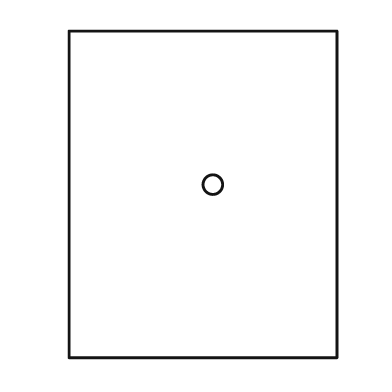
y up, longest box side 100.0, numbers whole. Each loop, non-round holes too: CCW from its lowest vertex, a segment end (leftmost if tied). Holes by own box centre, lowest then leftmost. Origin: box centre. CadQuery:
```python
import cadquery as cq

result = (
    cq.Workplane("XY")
    .moveTo(-41.0, -50.0)
    .lineTo(41.0, -50.0)
    .lineTo(41.0, 50.0)
    .lineTo(-41.0, 50.0)
    .close()
    .moveTo(3.0, 3.0)
    .circle(3.0)
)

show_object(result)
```